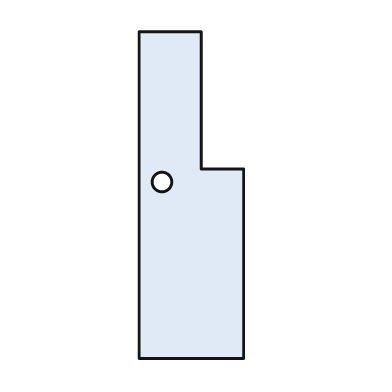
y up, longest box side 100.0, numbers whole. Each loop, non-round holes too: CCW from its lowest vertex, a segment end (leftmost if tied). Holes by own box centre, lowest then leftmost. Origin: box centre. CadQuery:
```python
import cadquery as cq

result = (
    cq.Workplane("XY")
    .moveTo(-16.0, -50.0)
    .lineTo(16.0, -50.0)
    .lineTo(16.0, 8.0)
    .lineTo(3.0, 8.0)
    .lineTo(3.0, 50.0)
    .lineTo(-16.0, 50.0)
    .close()
    .moveTo(-9.0, 4.0)
    .circle(3.0)
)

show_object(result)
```